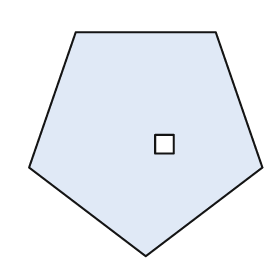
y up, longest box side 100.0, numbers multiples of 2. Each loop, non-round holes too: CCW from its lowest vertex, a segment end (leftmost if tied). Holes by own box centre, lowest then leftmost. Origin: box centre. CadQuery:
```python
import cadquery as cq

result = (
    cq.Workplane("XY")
    .moveTo(0.0, -48.0)
    .lineTo(50.0, -10.0)
    .lineTo(30.0, 48.0)
    .lineTo(-30.0, 48.0)
    .lineTo(-50.0, -10.0)
    .close()
    .moveTo(4.0, -4.0)
    .lineTo(12.0, -4.0)
    .lineTo(12.0, 4.0)
    .lineTo(4.0, 4.0)
    .close()
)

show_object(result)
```